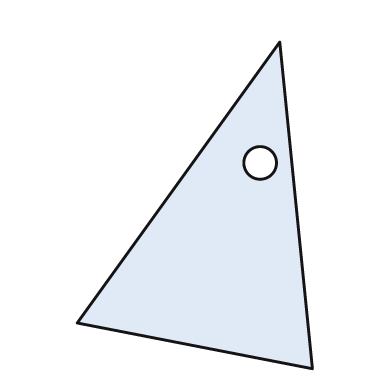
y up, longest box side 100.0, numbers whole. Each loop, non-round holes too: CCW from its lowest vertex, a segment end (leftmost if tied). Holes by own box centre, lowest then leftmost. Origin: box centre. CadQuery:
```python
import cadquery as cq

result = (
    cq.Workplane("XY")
    .moveTo(36.0, -50.0)
    .lineTo(26.0, 50.0)
    .lineTo(-36.0, -36.0)
    .close()
    .moveTo(20.0, 13.0)
    .circle(5.0)
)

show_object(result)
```